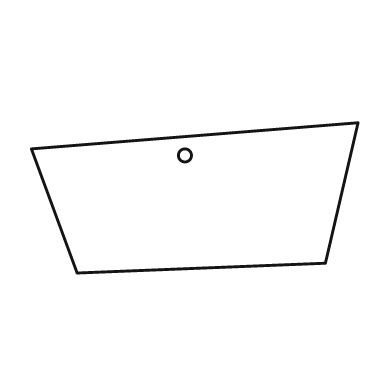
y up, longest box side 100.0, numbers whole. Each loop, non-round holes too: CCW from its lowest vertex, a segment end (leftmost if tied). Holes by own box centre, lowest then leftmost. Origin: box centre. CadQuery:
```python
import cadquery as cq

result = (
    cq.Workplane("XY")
    .moveTo(-36.0, -23.0)
    .lineTo(40.0, -20.0)
    .lineTo(50.0, 23.0)
    .lineTo(-50.0, 15.0)
    .close()
    .moveTo(-3.0, 13.0)
    .circle(2.0)
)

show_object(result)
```